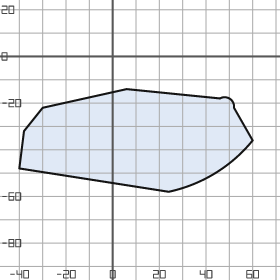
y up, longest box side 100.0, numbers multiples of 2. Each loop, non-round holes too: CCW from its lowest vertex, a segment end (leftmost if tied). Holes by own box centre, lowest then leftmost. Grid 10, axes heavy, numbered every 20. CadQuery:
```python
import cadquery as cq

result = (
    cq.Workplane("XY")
    .moveTo(24.0, -58.0)
    .threePointArc((44.0, -50.0), (60.0, -36.0))
    .lineTo(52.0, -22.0)
    .threePointArc((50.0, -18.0), (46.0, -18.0))
    .lineTo(6.0, -14.0)
    .lineTo(-30.0, -22.0)
    .lineTo(-38.0, -32.0)
    .lineTo(-40.0, -48.0)
    .close()
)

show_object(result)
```